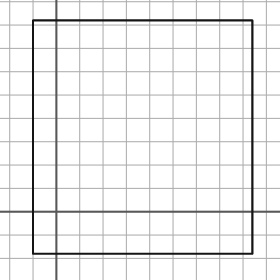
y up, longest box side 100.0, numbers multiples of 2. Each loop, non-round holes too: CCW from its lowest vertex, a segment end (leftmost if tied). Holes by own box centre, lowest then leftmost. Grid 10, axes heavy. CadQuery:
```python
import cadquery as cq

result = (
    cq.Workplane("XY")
    .moveTo(-10.0, -18.0)
    .lineTo(84.0, -18.0)
    .lineTo(84.0, 82.0)
    .lineTo(-10.0, 82.0)
    .close()
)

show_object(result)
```